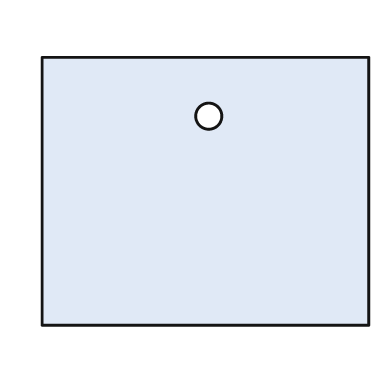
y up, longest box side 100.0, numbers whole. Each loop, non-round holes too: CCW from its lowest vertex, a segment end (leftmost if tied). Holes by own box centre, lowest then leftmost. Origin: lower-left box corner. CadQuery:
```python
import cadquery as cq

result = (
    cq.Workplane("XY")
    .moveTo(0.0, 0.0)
    .lineTo(100.0, 0.0)
    .lineTo(100.0, 82.0)
    .lineTo(0.0, 82.0)
    .close()
    .moveTo(51.0, 64.0)
    .circle(4.0)
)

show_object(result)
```